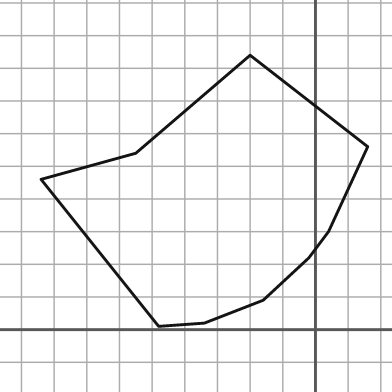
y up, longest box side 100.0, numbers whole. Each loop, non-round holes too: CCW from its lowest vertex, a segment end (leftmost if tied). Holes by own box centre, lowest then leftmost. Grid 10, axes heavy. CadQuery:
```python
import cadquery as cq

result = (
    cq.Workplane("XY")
    .moveTo(-48.0, 1.0)
    .lineTo(-34.0, 2.0)
    .lineTo(-16.0, 9.0)
    .lineTo(-2.0, 22.0)
    .lineTo(4.0, 30.0)
    .lineTo(16.0, 56.0)
    .lineTo(-20.0, 84.0)
    .lineTo(-55.0, 54.0)
    .lineTo(-84.0, 46.0)
    .close()
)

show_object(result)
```